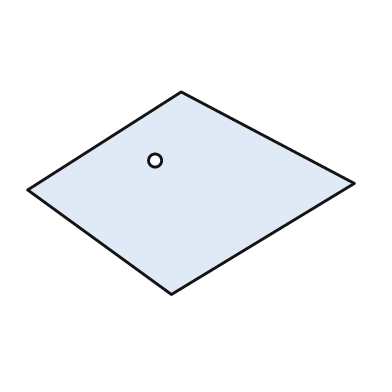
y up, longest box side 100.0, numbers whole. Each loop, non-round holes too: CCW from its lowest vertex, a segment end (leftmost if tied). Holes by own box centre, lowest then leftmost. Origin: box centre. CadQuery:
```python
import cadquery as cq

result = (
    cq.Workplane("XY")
    .moveTo(-6.0, -31.0)
    .lineTo(50.0, 3.0)
    .lineTo(-3.0, 31.0)
    .lineTo(-50.0, 1.0)
    .close()
    .moveTo(-11.0, 10.0)
    .circle(2.0)
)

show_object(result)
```